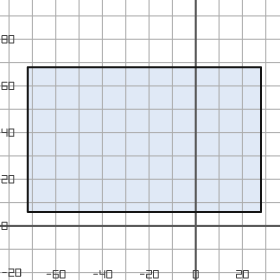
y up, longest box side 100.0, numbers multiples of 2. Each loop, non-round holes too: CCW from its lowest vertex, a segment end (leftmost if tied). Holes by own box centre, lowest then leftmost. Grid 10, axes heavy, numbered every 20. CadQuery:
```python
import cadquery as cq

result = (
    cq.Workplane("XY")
    .moveTo(-72.0, 6.0)
    .lineTo(28.0, 6.0)
    .lineTo(28.0, 68.0)
    .lineTo(-72.0, 68.0)
    .close()
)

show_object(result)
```